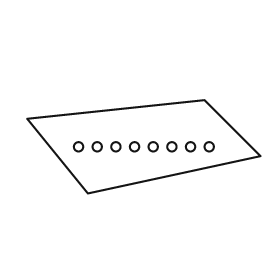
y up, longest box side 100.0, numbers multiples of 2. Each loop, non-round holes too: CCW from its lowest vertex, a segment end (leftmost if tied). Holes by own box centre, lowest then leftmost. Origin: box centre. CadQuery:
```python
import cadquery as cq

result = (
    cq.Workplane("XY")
    .moveTo(-24.0, -20.0)
    .lineTo(50.0, -4.0)
    .lineTo(26.0, 20.0)
    .lineTo(-50.0, 12.0)
    .close()
    .moveTo(-28.0, 0.0)
    .circle(2.0)
    .moveTo(-20.0, 0.0)
    .circle(2.0)
    .moveTo(-12.0, 0.0)
    .circle(2.0)
    .moveTo(-4.0, 0.0)
    .circle(2.0)
    .moveTo(4.0, 0.0)
    .circle(2.0)
    .moveTo(12.0, 0.0)
    .circle(2.0)
    .moveTo(20.0, 0.0)
    .circle(2.0)
    .moveTo(28.0, 0.0)
    .circle(2.0)
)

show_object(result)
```